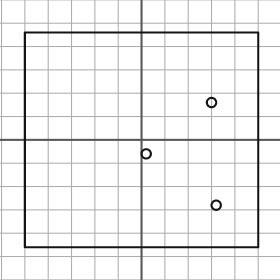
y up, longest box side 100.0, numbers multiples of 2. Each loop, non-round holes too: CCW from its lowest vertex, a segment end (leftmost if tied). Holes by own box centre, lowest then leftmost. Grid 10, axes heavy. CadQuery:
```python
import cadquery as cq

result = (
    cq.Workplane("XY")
    .moveTo(-50.0, -46.0)
    .lineTo(50.0, -46.0)
    .lineTo(50.0, 46.0)
    .lineTo(-50.0, 46.0)
    .close()
    .moveTo(32.0, -28.0)
    .circle(2.0)
    .moveTo(2.0, -6.0)
    .circle(2.0)
    .moveTo(30.0, 16.0)
    .circle(2.0)
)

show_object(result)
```